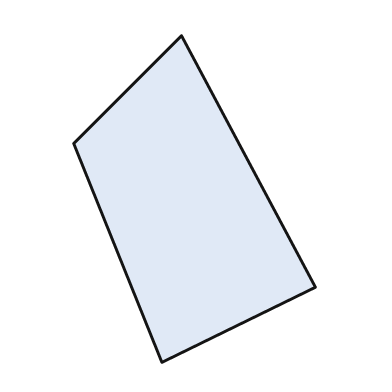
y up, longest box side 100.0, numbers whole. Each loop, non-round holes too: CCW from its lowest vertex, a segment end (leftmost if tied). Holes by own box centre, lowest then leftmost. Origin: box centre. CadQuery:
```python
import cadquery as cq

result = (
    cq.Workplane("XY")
    .moveTo(-10.0, -50.0)
    .lineTo(37.0, -27.0)
    .lineTo(-4.0, 50.0)
    .lineTo(-37.0, 17.0)
    .close()
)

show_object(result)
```